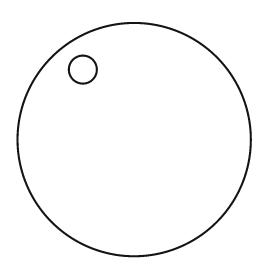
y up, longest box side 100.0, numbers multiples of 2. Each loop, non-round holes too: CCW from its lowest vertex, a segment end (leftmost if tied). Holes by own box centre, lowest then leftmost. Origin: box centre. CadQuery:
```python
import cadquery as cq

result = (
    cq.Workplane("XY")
    .moveTo(0.0, 0.0)
    .circle(50.0)
    .moveTo(-22.0, 30.0)
    .circle(6.0)
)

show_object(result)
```